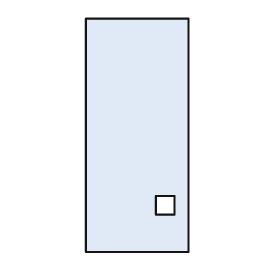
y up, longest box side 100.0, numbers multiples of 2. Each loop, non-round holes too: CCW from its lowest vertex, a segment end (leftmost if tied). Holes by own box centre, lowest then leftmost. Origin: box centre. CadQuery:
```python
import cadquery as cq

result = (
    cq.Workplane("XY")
    .moveTo(-22.0, -50.0)
    .lineTo(22.0, -50.0)
    .lineTo(22.0, 50.0)
    .lineTo(-22.0, 50.0)
    .close()
    .moveTo(8.0, -34.0)
    .lineTo(16.0, -34.0)
    .lineTo(16.0, -26.0)
    .lineTo(8.0, -26.0)
    .close()
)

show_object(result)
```